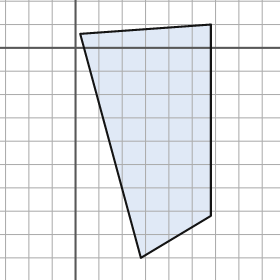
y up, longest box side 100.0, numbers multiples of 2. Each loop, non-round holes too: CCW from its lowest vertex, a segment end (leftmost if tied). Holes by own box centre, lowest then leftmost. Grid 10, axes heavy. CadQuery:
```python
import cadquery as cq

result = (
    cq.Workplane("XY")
    .moveTo(28.0, -90.0)
    .lineTo(58.0, -72.0)
    .lineTo(58.0, 10.0)
    .lineTo(2.0, 6.0)
    .close()
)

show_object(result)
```